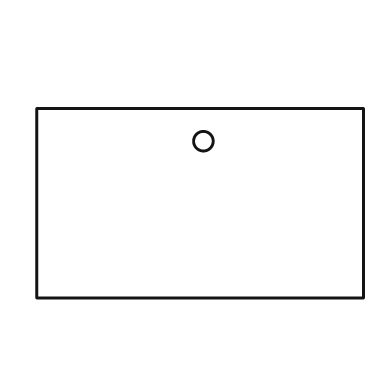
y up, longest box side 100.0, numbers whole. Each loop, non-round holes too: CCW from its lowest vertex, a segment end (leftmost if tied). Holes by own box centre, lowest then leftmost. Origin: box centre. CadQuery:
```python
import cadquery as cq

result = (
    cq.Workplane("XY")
    .moveTo(-50.0, -29.0)
    .lineTo(50.0, -29.0)
    .lineTo(50.0, 29.0)
    .lineTo(-50.0, 29.0)
    .close()
    .moveTo(1.0, 19.0)
    .circle(3.0)
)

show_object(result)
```